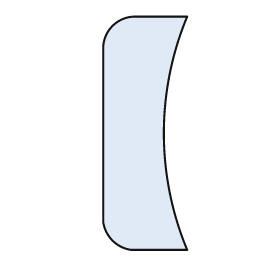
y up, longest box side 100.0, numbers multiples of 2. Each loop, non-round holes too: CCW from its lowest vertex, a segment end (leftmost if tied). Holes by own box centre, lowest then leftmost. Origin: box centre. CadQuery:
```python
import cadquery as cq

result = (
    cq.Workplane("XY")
    .moveTo(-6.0, -50.0)
    .lineTo(18.0, -50.0)
    .threePointArc((8.0, 0.0), (18.0, 50.0))
    .lineTo(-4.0, 50.0)
    .threePointArc((-14.0, 46.0), (-18.0, 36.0))
    .lineTo(-18.0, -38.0)
    .threePointArc((-14.0, -46.0), (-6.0, -50.0))
    .close()
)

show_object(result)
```